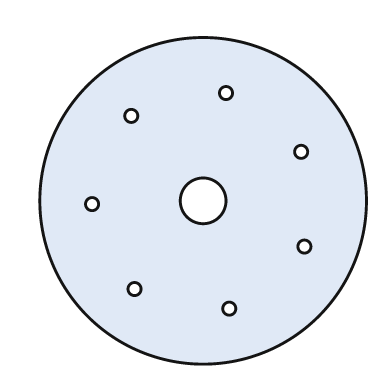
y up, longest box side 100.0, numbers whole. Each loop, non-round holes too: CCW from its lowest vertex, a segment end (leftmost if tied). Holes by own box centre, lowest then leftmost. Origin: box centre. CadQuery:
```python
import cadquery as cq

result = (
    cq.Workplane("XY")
    .moveTo(0.0, 0.0)
    .circle(50.0)
    .moveTo(8.0, -33.0)
    .circle(2.0)
    .moveTo(-21.0, -27.0)
    .circle(2.0)
    .moveTo(31.0, -14.0)
    .circle(2.0)
    .moveTo(-34.0, -1.0)
    .circle(2.0)
    .moveTo(0.0, 0.0)
    .circle(7.0)
    .moveTo(30.0, 15.0)
    .circle(2.0)
    .moveTo(-22.0, 26.0)
    .circle(2.0)
    .moveTo(7.0, 33.0)
    .circle(2.0)
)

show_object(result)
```